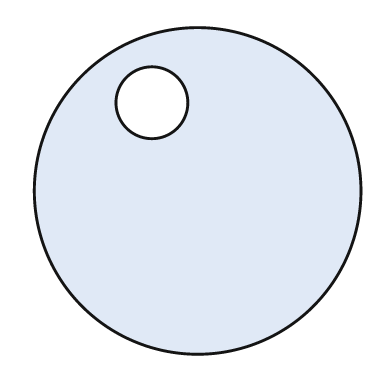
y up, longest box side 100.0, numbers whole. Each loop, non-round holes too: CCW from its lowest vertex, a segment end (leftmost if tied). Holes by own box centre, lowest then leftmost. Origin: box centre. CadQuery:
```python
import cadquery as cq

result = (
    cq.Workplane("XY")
    .moveTo(0.0, 0.0)
    .circle(50.0)
    .moveTo(-14.0, 27.0)
    .circle(11.0)
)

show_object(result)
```